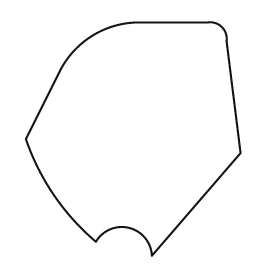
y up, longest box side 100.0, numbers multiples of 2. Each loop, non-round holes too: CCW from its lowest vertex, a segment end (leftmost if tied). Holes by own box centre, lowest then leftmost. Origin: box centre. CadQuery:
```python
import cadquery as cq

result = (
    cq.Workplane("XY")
    .moveTo(8.0, -50.0)
    .lineTo(46.0, -6.0)
    .lineTo(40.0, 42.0)
    .threePointArc((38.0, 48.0), (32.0, 50.0))
    .lineTo(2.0, 50.0)
    .threePointArc((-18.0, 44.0), (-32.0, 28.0))
    .lineTo(-46.0, 0.0)
    .threePointArc((-34.0, -24.0), (-16.0, -44.0))
    .threePointArc((-2.0, -38.0), (8.0, -50.0))
    .close()
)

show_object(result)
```